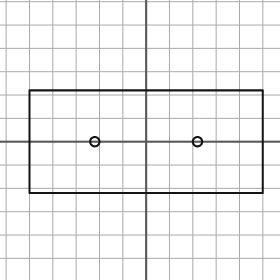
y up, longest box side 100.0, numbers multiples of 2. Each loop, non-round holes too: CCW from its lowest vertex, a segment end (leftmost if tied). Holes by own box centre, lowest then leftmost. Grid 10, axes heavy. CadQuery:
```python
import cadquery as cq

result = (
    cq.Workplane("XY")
    .moveTo(-50.0, -22.0)
    .lineTo(50.0, -22.0)
    .lineTo(50.0, 22.0)
    .lineTo(-50.0, 22.0)
    .close()
    .moveTo(-22.0, 0.0)
    .circle(2.0)
    .moveTo(22.0, 0.0)
    .circle(2.0)
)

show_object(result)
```